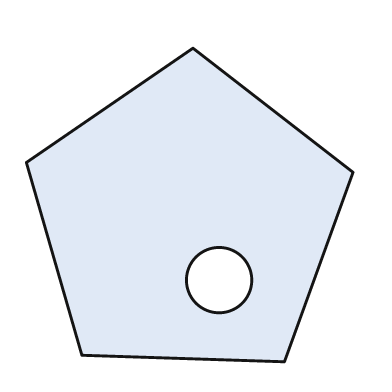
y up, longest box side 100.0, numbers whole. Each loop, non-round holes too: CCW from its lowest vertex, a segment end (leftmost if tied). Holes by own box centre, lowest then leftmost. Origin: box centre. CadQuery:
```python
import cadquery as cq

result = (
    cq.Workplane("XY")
    .moveTo(29.0, -48.0)
    .lineTo(50.0, 10.0)
    .lineTo(1.0, 48.0)
    .lineTo(-50.0, 13.0)
    .lineTo(-33.0, -46.0)
    .close()
    .moveTo(9.0, -23.0)
    .circle(10.0)
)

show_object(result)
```